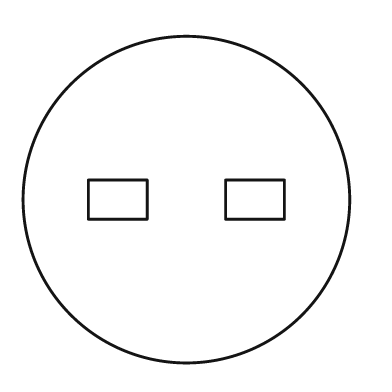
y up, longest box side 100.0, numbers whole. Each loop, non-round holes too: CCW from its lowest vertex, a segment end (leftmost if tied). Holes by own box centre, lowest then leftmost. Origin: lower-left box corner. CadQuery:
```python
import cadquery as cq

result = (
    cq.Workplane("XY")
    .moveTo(50.0, 50.0)
    .circle(50.0)
    .moveTo(20.0, 44.0)
    .lineTo(38.0, 44.0)
    .lineTo(38.0, 56.0)
    .lineTo(20.0, 56.0)
    .close()
    .moveTo(62.0, 44.0)
    .lineTo(80.0, 44.0)
    .lineTo(80.0, 56.0)
    .lineTo(62.0, 56.0)
    .close()
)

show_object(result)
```